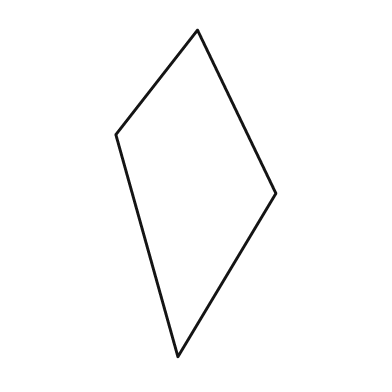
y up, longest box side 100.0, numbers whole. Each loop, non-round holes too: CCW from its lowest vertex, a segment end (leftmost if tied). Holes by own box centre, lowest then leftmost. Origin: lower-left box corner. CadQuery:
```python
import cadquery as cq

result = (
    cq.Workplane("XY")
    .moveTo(19.0, 0.0)
    .lineTo(49.0, 50.0)
    .lineTo(25.0, 100.0)
    .lineTo(0.0, 68.0)
    .close()
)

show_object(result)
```